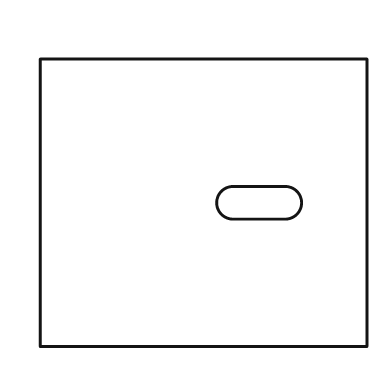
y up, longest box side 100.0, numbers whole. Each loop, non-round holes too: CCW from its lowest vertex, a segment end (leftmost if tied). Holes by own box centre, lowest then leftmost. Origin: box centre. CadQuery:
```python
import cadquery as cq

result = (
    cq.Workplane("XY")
    .moveTo(-50.0, -44.0)
    .lineTo(50.0, -44.0)
    .lineTo(50.0, 44.0)
    .lineTo(-50.0, 44.0)
    .close()
    .moveTo(9.0, -5.0)
    .lineTo(25.0, -5.0)
    .threePointArc((30.0, 0.0), (25.0, 5.0))
    .lineTo(9.0, 5.0)
    .threePointArc((4.0, 0.0), (9.0, -5.0))
    .close()
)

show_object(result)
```